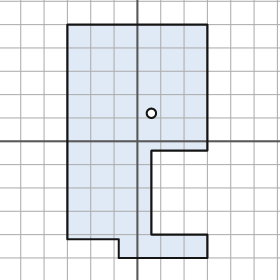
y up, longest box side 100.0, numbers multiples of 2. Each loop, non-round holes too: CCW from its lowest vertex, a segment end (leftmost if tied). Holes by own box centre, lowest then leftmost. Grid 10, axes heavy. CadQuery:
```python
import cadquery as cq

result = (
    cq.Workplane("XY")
    .moveTo(-8.0, -50.0)
    .lineTo(30.0, -50.0)
    .lineTo(30.0, -40.0)
    .lineTo(6.0, -40.0)
    .lineTo(6.0, -4.0)
    .lineTo(30.0, -4.0)
    .lineTo(30.0, 50.0)
    .lineTo(-30.0, 50.0)
    .lineTo(-30.0, -42.0)
    .lineTo(-8.0, -42.0)
    .close()
    .moveTo(6.0, 12.0)
    .circle(2.0)
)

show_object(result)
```